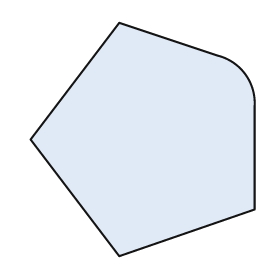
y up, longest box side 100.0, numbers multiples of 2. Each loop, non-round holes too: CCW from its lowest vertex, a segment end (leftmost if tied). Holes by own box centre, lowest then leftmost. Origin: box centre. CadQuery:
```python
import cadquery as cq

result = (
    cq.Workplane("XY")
    .moveTo(-10.0, -50.0)
    .lineTo(48.0, -30.0)
    .lineTo(48.0, 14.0)
    .threePointArc((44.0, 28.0), (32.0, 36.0))
    .lineTo(-10.0, 50.0)
    .lineTo(-48.0, 0.0)
    .close()
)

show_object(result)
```